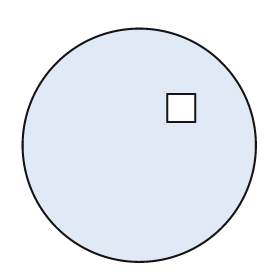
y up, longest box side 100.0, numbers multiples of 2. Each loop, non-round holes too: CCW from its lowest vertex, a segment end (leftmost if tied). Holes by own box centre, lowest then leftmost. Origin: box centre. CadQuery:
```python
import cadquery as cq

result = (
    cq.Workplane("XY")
    .moveTo(0.0, 0.0)
    .circle(50.0)
    .moveTo(12.0, 10.0)
    .lineTo(24.0, 10.0)
    .lineTo(24.0, 22.0)
    .lineTo(12.0, 22.0)
    .close()
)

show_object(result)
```